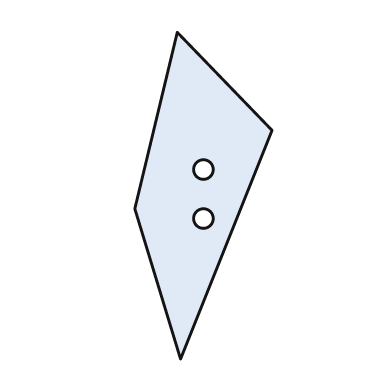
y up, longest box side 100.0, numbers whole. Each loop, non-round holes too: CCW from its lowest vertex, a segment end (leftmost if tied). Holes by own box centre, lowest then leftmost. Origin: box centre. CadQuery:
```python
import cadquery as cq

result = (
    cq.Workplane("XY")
    .moveTo(-7.0, -50.0)
    .lineTo(21.0, 20.0)
    .lineTo(-8.0, 50.0)
    .lineTo(-21.0, -4.0)
    .close()
    .moveTo(0.0, -7.0)
    .circle(3.0)
    .moveTo(0.0, 8.0)
    .circle(3.0)
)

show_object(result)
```